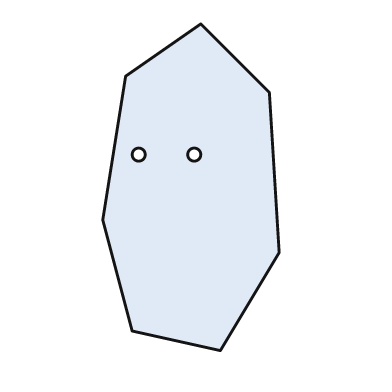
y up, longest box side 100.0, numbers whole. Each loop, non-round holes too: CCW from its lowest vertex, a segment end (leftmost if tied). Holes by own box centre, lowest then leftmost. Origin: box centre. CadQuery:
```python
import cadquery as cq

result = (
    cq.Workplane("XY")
    .moveTo(9.0, -50.0)
    .lineTo(27.0, -20.0)
    .lineTo(24.0, 29.0)
    .lineTo(3.0, 50.0)
    .lineTo(-20.0, 34.0)
    .lineTo(-27.0, -10.0)
    .lineTo(-18.0, -44.0)
    .close()
    .moveTo(-16.0, 10.0)
    .circle(2.0)
    .moveTo(1.0, 10.0)
    .circle(2.0)
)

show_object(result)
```